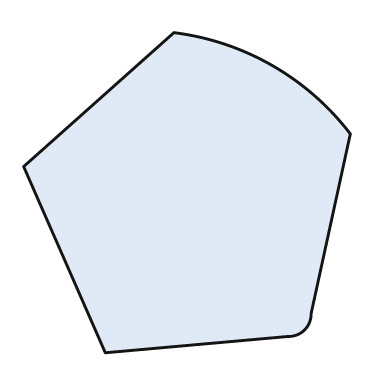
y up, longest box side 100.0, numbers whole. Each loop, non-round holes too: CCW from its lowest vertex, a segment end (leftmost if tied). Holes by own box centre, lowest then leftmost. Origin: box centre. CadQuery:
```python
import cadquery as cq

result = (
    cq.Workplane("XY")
    .moveTo(-25.0, -49.0)
    .lineTo(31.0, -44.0)
    .threePointArc((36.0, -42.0), (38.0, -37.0))
    .lineTo(50.0, 18.0)
    .threePointArc((26.0, 39.0), (-4.0, 49.0))
    .lineTo(-50.0, 8.0)
    .close()
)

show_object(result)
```